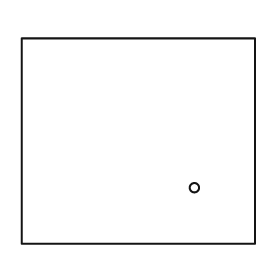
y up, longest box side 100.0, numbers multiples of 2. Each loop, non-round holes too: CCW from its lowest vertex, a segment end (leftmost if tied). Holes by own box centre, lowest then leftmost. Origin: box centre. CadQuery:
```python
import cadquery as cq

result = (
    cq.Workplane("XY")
    .moveTo(-50.0, -44.0)
    .lineTo(50.0, -44.0)
    .lineTo(50.0, 44.0)
    .lineTo(-50.0, 44.0)
    .close()
    .moveTo(24.0, -20.0)
    .circle(2.0)
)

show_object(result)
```